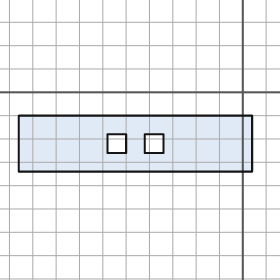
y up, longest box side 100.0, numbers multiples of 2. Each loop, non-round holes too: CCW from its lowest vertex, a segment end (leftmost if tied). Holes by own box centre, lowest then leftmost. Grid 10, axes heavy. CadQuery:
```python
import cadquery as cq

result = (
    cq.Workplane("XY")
    .moveTo(-96.0, -34.0)
    .lineTo(4.0, -34.0)
    .lineTo(4.0, -10.0)
    .lineTo(-96.0, -10.0)
    .close()
    .moveTo(-58.0, -26.0)
    .lineTo(-50.0, -26.0)
    .lineTo(-50.0, -18.0)
    .lineTo(-58.0, -18.0)
    .close()
    .moveTo(-42.0, -26.0)
    .lineTo(-34.0, -26.0)
    .lineTo(-34.0, -18.0)
    .lineTo(-42.0, -18.0)
    .close()
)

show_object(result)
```